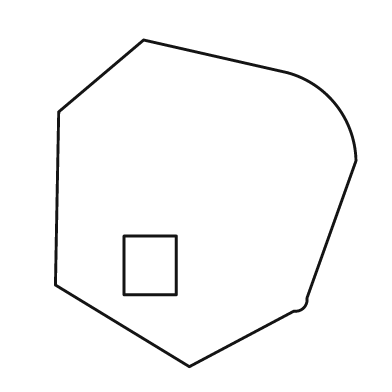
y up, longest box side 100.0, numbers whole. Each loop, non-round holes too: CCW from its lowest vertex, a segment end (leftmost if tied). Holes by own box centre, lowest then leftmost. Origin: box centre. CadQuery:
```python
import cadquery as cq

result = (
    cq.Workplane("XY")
    .moveTo(-5.0, -50.0)
    .lineTo(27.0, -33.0)
    .threePointArc((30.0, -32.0), (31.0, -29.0))
    .lineTo(46.0, 13.0)
    .threePointArc((40.0, 30.0), (25.0, 40.0))
    .lineTo(-19.0, 50.0)
    .lineTo(-45.0, 28.0)
    .lineTo(-46.0, -25.0)
    .close()
    .moveTo(-25.0, -28.0)
    .lineTo(-9.0, -28.0)
    .lineTo(-9.0, -10.0)
    .lineTo(-25.0, -10.0)
    .close()
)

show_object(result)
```